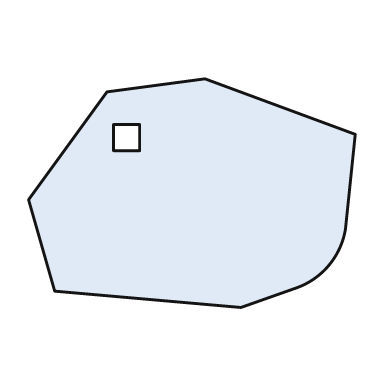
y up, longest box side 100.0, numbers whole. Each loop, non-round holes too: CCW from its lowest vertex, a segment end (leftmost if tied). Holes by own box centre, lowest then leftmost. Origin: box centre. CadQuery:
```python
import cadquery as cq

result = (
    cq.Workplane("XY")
    .moveTo(15.0, -35.0)
    .lineTo(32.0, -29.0)
    .threePointArc((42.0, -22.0), (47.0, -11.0))
    .lineTo(50.0, 18.0)
    .lineTo(4.0, 35.0)
    .lineTo(-26.0, 31.0)
    .lineTo(-50.0, -2.0)
    .lineTo(-42.0, -30.0)
    .close()
    .moveTo(-24.0, 13.0)
    .lineTo(-16.0, 13.0)
    .lineTo(-16.0, 21.0)
    .lineTo(-24.0, 21.0)
    .close()
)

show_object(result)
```